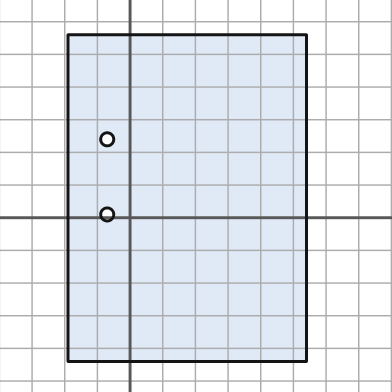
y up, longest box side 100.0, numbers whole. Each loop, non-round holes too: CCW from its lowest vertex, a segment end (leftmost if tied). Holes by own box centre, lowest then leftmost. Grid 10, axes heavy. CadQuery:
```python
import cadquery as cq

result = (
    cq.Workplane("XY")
    .moveTo(-19.0, -44.0)
    .lineTo(54.0, -44.0)
    .lineTo(54.0, 56.0)
    .lineTo(-19.0, 56.0)
    .close()
    .moveTo(-7.0, 1.0)
    .circle(2.0)
    .moveTo(-7.0, 24.0)
    .circle(2.0)
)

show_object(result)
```